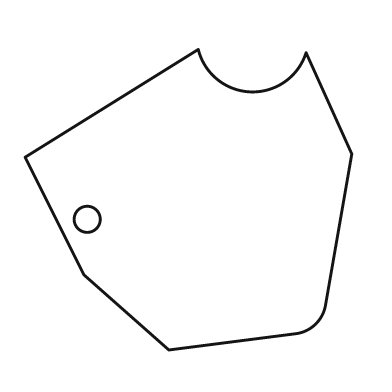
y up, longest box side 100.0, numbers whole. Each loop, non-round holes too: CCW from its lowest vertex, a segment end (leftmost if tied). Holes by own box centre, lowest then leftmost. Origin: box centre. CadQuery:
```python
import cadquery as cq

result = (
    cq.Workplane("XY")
    .moveTo(-6.0, -46.0)
    .lineTo(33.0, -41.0)
    .threePointArc((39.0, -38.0), (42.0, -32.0))
    .lineTo(50.0, 14.0)
    .lineTo(36.0, 45.0)
    .threePointArc((19.0, 33.0), (3.0, 46.0))
    .lineTo(-50.0, 13.0)
    .lineTo(-32.0, -23.0)
    .close()
    .moveTo(-31.0, -6.0)
    .circle(4.0)
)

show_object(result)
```